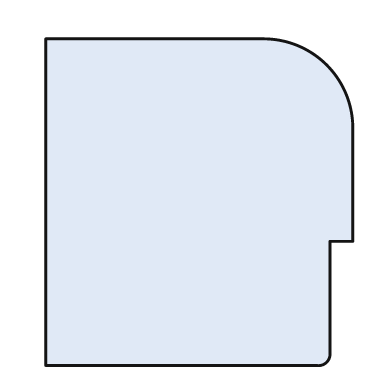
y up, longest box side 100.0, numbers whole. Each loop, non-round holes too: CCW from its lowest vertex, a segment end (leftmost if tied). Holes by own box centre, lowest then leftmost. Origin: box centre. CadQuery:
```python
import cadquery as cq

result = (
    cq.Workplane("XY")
    .moveTo(-47.0, -50.0)
    .lineTo(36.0, -50.0)
    .threePointArc((39.0, -49.0), (40.0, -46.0))
    .lineTo(40.0, -12.0)
    .lineTo(47.0, -12.0)
    .lineTo(47.0, 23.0)
    .threePointArc((39.0, 42.0), (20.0, 50.0))
    .lineTo(-47.0, 50.0)
    .close()
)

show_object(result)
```